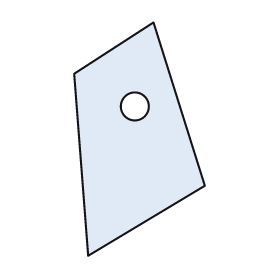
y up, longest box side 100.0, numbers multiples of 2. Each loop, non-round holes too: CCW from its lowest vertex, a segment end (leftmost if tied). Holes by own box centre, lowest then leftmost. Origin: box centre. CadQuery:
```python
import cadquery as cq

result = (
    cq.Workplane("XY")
    .moveTo(-22.0, -50.0)
    .lineTo(28.0, -20.0)
    .lineTo(6.0, 50.0)
    .lineTo(-28.0, 28.0)
    .close()
    .moveTo(-2.0, 14.0)
    .circle(6.0)
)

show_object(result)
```